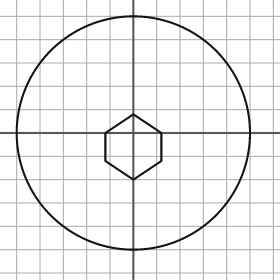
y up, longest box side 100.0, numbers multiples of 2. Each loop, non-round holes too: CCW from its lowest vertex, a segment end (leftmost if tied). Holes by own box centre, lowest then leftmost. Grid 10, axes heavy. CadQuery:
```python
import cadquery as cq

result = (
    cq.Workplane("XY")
    .moveTo(0.0, 0.0)
    .circle(50.0)
    .moveTo(0.0, -20.0)
    .lineTo(12.0, -12.0)
    .lineTo(12.0, 0.0)
    .lineTo(0.0, 8.0)
    .lineTo(-12.0, 0.0)
    .lineTo(-12.0, -12.0)
    .close()
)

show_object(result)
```